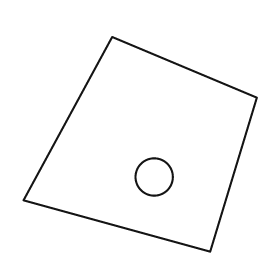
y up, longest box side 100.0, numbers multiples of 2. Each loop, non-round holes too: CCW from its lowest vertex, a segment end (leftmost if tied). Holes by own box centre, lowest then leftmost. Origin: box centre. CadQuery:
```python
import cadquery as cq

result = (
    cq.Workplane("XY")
    .moveTo(30.0, -46.0)
    .lineTo(50.0, 20.0)
    .lineTo(-12.0, 46.0)
    .lineTo(-50.0, -24.0)
    .close()
    .moveTo(6.0, -14.0)
    .circle(8.0)
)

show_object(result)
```